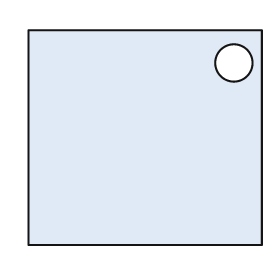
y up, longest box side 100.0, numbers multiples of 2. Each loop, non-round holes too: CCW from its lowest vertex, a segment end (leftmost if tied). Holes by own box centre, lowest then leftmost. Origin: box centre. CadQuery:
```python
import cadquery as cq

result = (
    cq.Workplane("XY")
    .moveTo(-50.0, -46.0)
    .lineTo(50.0, -46.0)
    .lineTo(50.0, 46.0)
    .lineTo(-50.0, 46.0)
    .close()
    .moveTo(38.0, 32.0)
    .circle(8.0)
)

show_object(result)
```